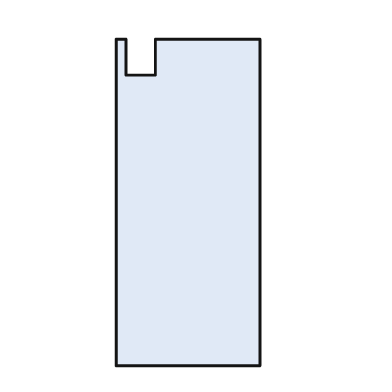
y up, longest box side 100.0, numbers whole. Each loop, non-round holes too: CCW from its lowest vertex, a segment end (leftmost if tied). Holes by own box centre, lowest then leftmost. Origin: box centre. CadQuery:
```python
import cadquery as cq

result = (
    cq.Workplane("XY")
    .moveTo(-22.0, -50.0)
    .lineTo(22.0, -50.0)
    .lineTo(22.0, 50.0)
    .lineTo(-10.0, 50.0)
    .lineTo(-10.0, 39.0)
    .lineTo(-19.0, 39.0)
    .lineTo(-19.0, 50.0)
    .lineTo(-22.0, 50.0)
    .close()
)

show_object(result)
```